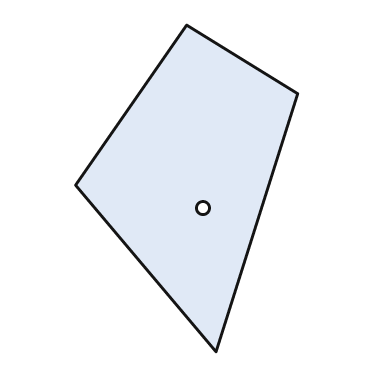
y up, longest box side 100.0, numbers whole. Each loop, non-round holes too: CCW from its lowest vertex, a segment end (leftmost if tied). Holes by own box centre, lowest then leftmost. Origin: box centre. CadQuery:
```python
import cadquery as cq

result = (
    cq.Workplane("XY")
    .moveTo(9.0, -50.0)
    .lineTo(34.0, 29.0)
    .lineTo(0.0, 50.0)
    .lineTo(-34.0, 1.0)
    .close()
    .moveTo(5.0, -6.0)
    .circle(2.0)
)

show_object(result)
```